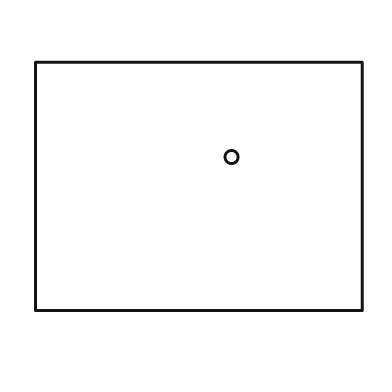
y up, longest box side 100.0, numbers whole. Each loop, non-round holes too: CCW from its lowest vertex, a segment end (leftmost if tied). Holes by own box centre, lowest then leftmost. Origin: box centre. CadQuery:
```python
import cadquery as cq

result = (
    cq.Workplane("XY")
    .moveTo(-50.0, -38.0)
    .lineTo(50.0, -38.0)
    .lineTo(50.0, 38.0)
    .lineTo(-50.0, 38.0)
    .close()
    .moveTo(10.0, 9.0)
    .circle(2.0)
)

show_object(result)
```